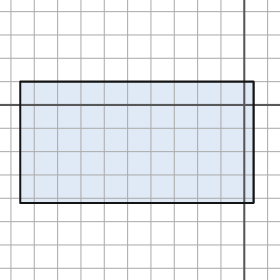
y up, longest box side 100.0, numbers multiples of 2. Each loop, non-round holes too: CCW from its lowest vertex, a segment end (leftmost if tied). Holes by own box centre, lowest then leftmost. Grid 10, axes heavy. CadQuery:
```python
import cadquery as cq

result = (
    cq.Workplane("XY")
    .moveTo(-96.0, -42.0)
    .lineTo(4.0, -42.0)
    .lineTo(4.0, 10.0)
    .lineTo(-96.0, 10.0)
    .close()
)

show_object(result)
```